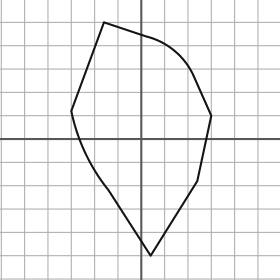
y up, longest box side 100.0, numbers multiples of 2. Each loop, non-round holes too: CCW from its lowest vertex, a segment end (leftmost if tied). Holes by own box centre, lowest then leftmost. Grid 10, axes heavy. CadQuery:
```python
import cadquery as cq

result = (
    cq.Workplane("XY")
    .moveTo(4.0, -50.0)
    .lineTo(24.0, -18.0)
    .lineTo(30.0, 10.0)
    .lineTo(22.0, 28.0)
    .threePointArc((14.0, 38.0), (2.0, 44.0))
    .lineTo(-16.0, 50.0)
    .lineTo(-30.0, 12.0)
    .threePointArc((-24.0, -6.0), (-14.0, -22.0))
    .close()
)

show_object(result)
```